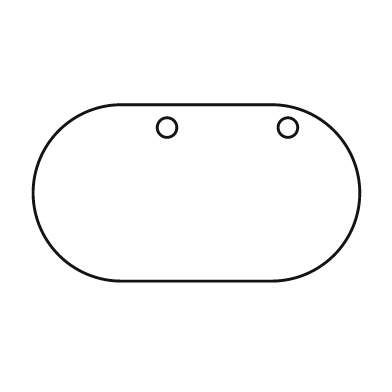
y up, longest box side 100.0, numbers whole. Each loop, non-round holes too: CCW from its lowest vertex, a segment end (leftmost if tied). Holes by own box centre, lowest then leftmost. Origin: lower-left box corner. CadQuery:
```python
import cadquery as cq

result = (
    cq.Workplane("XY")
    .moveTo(27.0, 0.0)
    .lineTo(73.0, 0.0)
    .threePointArc((100.0, 27.0), (73.0, 54.0))
    .lineTo(27.0, 54.0)
    .threePointArc((0.0, 27.0), (27.0, 0.0))
    .close()
    .moveTo(41.0, 47.0)
    .circle(3.0)
    .moveTo(78.0, 47.0)
    .circle(3.0)
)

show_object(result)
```